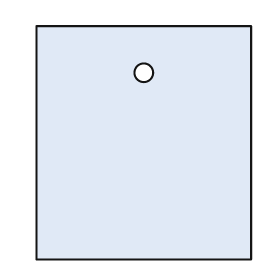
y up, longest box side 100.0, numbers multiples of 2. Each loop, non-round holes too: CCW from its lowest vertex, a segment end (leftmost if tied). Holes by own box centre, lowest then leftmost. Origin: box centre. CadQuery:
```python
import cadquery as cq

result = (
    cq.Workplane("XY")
    .moveTo(-46.0, -50.0)
    .lineTo(46.0, -50.0)
    .lineTo(46.0, 50.0)
    .lineTo(-46.0, 50.0)
    .close()
    .moveTo(0.0, 30.0)
    .circle(4.0)
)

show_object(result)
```